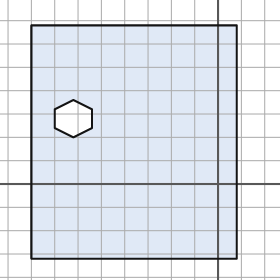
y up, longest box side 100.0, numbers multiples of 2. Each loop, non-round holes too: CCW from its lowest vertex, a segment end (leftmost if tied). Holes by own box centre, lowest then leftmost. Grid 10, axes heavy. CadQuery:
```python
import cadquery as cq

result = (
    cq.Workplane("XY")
    .moveTo(-80.0, -32.0)
    .lineTo(8.0, -32.0)
    .lineTo(8.0, 68.0)
    .lineTo(-80.0, 68.0)
    .close()
    .moveTo(-62.0, 20.0)
    .lineTo(-54.0, 24.0)
    .lineTo(-54.0, 32.0)
    .lineTo(-62.0, 36.0)
    .lineTo(-70.0, 32.0)
    .lineTo(-70.0, 24.0)
    .close()
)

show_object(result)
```